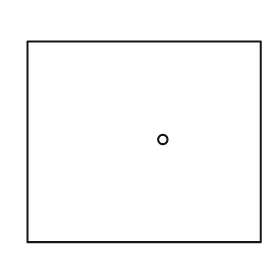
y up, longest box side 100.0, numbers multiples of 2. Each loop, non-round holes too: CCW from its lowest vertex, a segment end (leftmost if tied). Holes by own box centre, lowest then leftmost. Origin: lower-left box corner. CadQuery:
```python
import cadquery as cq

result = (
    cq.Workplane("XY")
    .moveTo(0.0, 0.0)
    .lineTo(100.0, 0.0)
    .lineTo(100.0, 86.0)
    .lineTo(0.0, 86.0)
    .close()
    .moveTo(58.0, 44.0)
    .circle(2.0)
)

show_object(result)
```